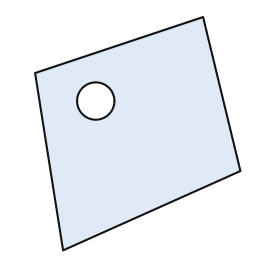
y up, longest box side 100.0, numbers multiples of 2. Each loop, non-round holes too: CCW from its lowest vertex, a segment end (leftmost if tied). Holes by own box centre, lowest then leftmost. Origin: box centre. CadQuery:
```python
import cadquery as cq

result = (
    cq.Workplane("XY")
    .moveTo(-32.0, -50.0)
    .lineTo(44.0, -16.0)
    .lineTo(28.0, 50.0)
    .lineTo(-44.0, 26.0)
    .close()
    .moveTo(-18.0, 14.0)
    .circle(8.0)
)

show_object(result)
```